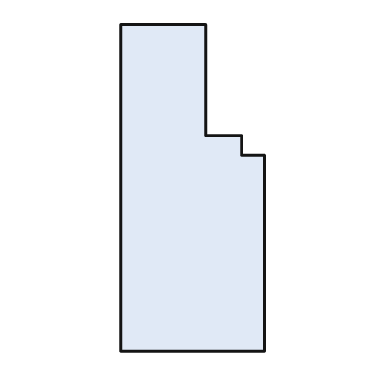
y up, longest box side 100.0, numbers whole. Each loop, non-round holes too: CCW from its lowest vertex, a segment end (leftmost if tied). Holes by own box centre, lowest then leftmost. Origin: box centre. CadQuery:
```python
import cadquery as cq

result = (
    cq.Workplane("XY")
    .moveTo(-22.0, -50.0)
    .lineTo(22.0, -50.0)
    .lineTo(22.0, 10.0)
    .lineTo(15.0, 10.0)
    .lineTo(15.0, 16.0)
    .lineTo(4.0, 16.0)
    .lineTo(4.0, 50.0)
    .lineTo(-22.0, 50.0)
    .close()
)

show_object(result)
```